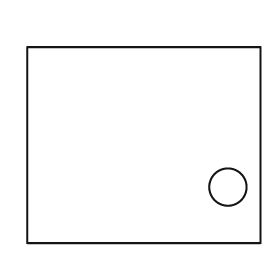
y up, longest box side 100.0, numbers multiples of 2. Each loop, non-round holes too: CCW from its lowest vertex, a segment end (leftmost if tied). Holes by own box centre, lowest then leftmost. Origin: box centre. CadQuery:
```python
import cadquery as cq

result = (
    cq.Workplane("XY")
    .moveTo(-50.0, -42.0)
    .lineTo(50.0, -42.0)
    .lineTo(50.0, 42.0)
    .lineTo(-50.0, 42.0)
    .close()
    .moveTo(36.0, -18.0)
    .circle(8.0)
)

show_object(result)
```